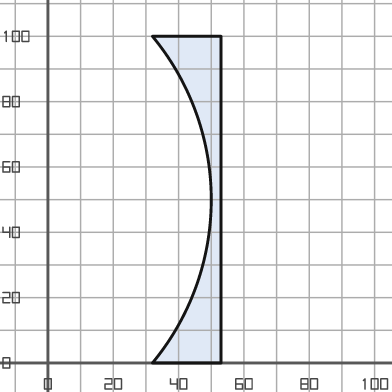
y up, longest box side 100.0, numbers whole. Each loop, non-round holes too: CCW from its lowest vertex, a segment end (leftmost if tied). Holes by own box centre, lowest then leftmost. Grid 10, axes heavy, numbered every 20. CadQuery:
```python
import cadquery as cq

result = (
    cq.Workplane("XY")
    .moveTo(32.0, 0.0)
    .lineTo(53.0, 0.0)
    .lineTo(53.0, 100.0)
    .lineTo(32.0, 100.0)
    .threePointArc((50.0, 50.0), (32.0, 0.0))
    .close()
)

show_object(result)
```